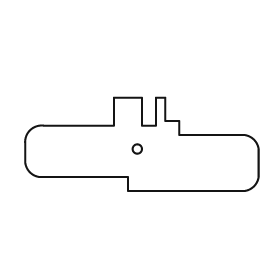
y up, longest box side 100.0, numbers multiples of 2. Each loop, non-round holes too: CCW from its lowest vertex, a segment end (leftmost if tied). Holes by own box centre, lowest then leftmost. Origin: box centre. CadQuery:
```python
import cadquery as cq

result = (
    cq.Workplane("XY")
    .moveTo(-6.0, -20.0)
    .lineTo(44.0, -20.0)
    .threePointArc((48.0, -18.0), (50.0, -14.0))
    .lineTo(50.0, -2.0)
    .threePointArc((48.0, 2.0), (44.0, 4.0))
    .lineTo(16.0, 4.0)
    .lineTo(16.0, 10.0)
    .lineTo(10.0, 10.0)
    .lineTo(10.0, 20.0)
    .lineTo(6.0, 20.0)
    .lineTo(6.0, 8.0)
    .lineTo(0.0, 8.0)
    .lineTo(0.0, 20.0)
    .lineTo(-12.0, 20.0)
    .lineTo(-12.0, 8.0)
    .lineTo(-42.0, 8.0)
    .threePointArc((-48.0, 6.0), (-50.0, 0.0))
    .lineTo(-50.0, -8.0)
    .threePointArc((-48.0, -12.0), (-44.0, -14.0))
    .lineTo(-6.0, -14.0)
    .close()
    .moveTo(-2.0, -2.0)
    .circle(2.0)
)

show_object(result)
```